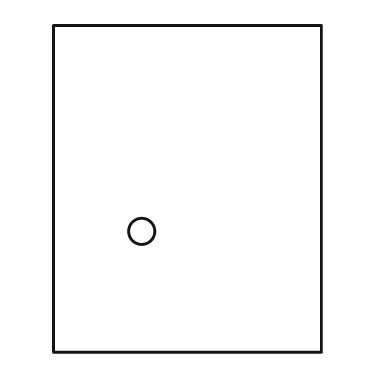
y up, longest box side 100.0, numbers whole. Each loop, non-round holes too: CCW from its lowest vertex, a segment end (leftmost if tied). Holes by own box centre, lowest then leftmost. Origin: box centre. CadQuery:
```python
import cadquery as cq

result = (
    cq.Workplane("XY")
    .moveTo(-41.0, -50.0)
    .lineTo(41.0, -50.0)
    .lineTo(41.0, 50.0)
    .lineTo(-41.0, 50.0)
    .close()
    .moveTo(-14.0, -13.0)
    .circle(4.0)
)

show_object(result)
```